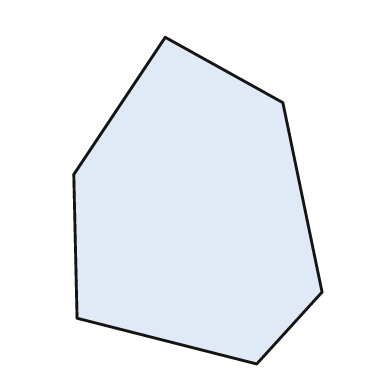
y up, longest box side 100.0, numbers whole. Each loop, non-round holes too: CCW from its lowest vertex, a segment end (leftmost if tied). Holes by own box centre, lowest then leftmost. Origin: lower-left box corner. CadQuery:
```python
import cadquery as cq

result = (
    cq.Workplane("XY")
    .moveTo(56.0, 0.0)
    .lineTo(76.0, 22.0)
    .lineTo(64.0, 80.0)
    .lineTo(28.0, 100.0)
    .lineTo(0.0, 58.0)
    .lineTo(1.0, 14.0)
    .close()
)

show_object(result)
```